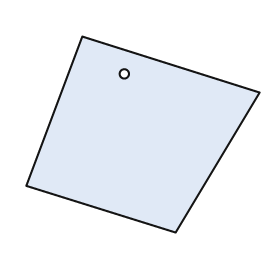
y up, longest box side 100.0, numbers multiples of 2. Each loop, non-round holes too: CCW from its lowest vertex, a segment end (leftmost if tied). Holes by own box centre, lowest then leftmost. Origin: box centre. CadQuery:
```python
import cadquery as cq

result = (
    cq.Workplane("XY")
    .moveTo(14.0, -42.0)
    .lineTo(50.0, 18.0)
    .lineTo(-26.0, 42.0)
    .lineTo(-50.0, -22.0)
    .close()
    .moveTo(-8.0, 26.0)
    .circle(2.0)
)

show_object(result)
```